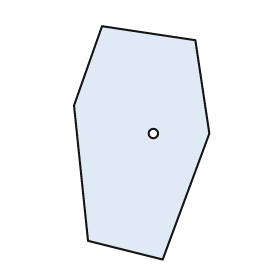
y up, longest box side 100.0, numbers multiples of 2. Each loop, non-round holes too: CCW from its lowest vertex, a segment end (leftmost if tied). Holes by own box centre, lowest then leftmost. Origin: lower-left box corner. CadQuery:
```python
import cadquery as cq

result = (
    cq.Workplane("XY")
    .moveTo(38.0, 0.0)
    .lineTo(58.0, 54.0)
    .lineTo(52.0, 94.0)
    .lineTo(12.0, 100.0)
    .lineTo(0.0, 66.0)
    .lineTo(6.0, 8.0)
    .close()
    .moveTo(34.0, 54.0)
    .circle(2.0)
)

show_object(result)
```